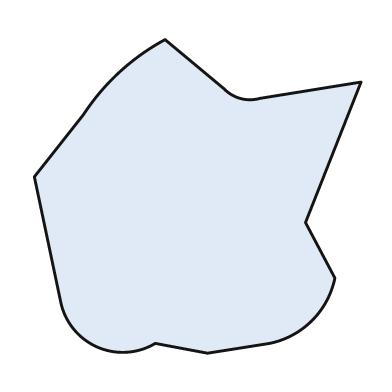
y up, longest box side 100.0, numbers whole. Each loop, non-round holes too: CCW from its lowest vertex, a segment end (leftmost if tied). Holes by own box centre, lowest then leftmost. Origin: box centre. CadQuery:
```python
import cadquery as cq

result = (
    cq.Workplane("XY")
    .moveTo(3.0, -48.0)
    .lineTo(22.0, -45.0)
    .threePointArc((35.0, -38.0), (42.0, -25.0))
    .lineTo(33.0, -8.0)
    .lineTo(50.0, 35.0)
    .lineTo(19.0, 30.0)
    .threePointArc((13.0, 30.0), (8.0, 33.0))
    .lineTo(-10.0, 48.0)
    .threePointArc((-24.0, 38.0), (-35.0, 25.0))
    .lineTo(-50.0, 6.0)
    .lineTo(-42.0, -32.0)
    .threePointArc((-31.0, -46.0), (-13.0, -45.0))
    .close()
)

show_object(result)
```